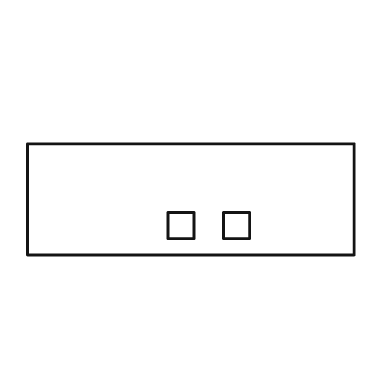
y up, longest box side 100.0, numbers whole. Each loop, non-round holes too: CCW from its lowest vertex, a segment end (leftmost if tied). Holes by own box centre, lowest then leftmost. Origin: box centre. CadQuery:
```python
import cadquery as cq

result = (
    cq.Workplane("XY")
    .moveTo(-50.0, -17.0)
    .lineTo(50.0, -17.0)
    .lineTo(50.0, 17.0)
    .lineTo(-50.0, 17.0)
    .close()
    .moveTo(-7.0, -12.0)
    .lineTo(1.0, -12.0)
    .lineTo(1.0, -4.0)
    .lineTo(-7.0, -4.0)
    .close()
    .moveTo(10.0, -12.0)
    .lineTo(18.0, -12.0)
    .lineTo(18.0, -4.0)
    .lineTo(10.0, -4.0)
    .close()
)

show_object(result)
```